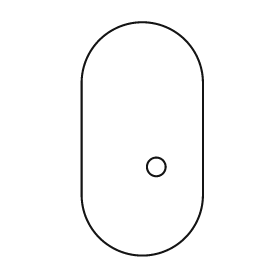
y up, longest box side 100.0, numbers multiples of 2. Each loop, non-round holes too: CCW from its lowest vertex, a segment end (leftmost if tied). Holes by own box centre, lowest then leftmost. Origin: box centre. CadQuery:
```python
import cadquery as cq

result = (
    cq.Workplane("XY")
    .moveTo(-26.0, -24.0)
    .threePointArc((0.0, -50.0), (26.0, -24.0))
    .lineTo(26.0, 24.0)
    .threePointArc((0.0, 50.0), (-26.0, 24.0))
    .close()
    .moveTo(6.0, -12.0)
    .circle(4.0)
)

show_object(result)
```